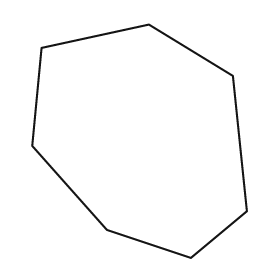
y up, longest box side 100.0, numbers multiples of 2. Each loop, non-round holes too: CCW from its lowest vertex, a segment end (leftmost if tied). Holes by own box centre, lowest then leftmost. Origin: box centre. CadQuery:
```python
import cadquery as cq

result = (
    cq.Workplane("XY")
    .moveTo(22.0, -50.0)
    .lineTo(46.0, -30.0)
    .lineTo(40.0, 28.0)
    .lineTo(4.0, 50.0)
    .lineTo(-42.0, 40.0)
    .lineTo(-46.0, -2.0)
    .lineTo(-14.0, -38.0)
    .close()
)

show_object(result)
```